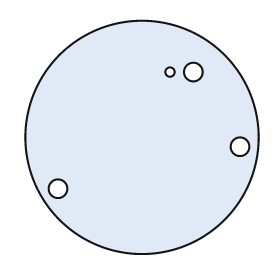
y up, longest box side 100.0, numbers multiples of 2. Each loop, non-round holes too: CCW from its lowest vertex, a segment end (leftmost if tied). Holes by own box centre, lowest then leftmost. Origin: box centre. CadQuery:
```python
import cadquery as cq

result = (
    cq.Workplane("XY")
    .moveTo(0.0, 0.0)
    .circle(50.0)
    .moveTo(-36.0, -22.0)
    .circle(4.0)
    .moveTo(42.0, -4.0)
    .circle(4.0)
    .moveTo(12.0, 28.0)
    .circle(2.0)
    .moveTo(22.0, 28.0)
    .circle(4.0)
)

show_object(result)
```